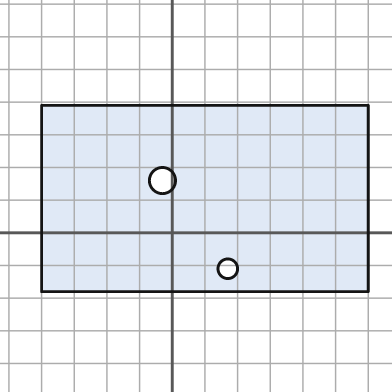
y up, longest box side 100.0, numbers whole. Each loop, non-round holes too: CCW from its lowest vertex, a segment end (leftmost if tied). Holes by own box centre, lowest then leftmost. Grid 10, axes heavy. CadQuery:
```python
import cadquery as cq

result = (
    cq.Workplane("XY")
    .moveTo(-40.0, -18.0)
    .lineTo(60.0, -18.0)
    .lineTo(60.0, 39.0)
    .lineTo(-40.0, 39.0)
    .close()
    .moveTo(17.0, -11.0)
    .circle(3.0)
    .moveTo(-3.0, 16.0)
    .circle(4.0)
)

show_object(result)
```